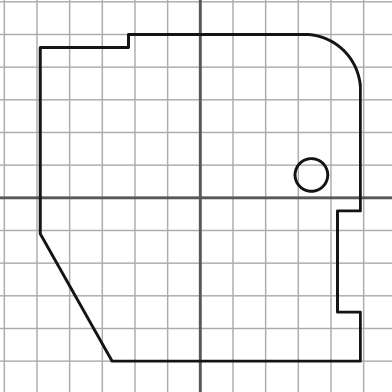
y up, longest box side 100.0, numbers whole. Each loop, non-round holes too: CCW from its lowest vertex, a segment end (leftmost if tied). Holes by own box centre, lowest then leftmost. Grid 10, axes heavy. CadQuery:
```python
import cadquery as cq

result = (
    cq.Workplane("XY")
    .moveTo(-27.0, -50.0)
    .lineTo(49.0, -50.0)
    .lineTo(49.0, -35.0)
    .lineTo(42.0, -35.0)
    .lineTo(42.0, -4.0)
    .lineTo(49.0, -4.0)
    .lineTo(49.0, 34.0)
    .threePointArc((44.0, 45.0), (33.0, 50.0))
    .lineTo(-22.0, 50.0)
    .lineTo(-22.0, 46.0)
    .lineTo(-49.0, 46.0)
    .lineTo(-49.0, -11.0)
    .close()
    .moveTo(34.0, 7.0)
    .circle(5.0)
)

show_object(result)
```